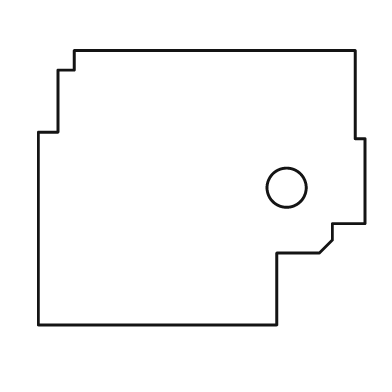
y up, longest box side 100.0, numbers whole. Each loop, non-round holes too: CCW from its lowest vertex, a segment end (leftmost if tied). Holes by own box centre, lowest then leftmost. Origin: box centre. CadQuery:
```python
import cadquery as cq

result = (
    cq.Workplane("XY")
    .moveTo(-50.0, -42.0)
    .lineTo(23.0, -42.0)
    .lineTo(23.0, -20.0)
    .lineTo(36.0, -20.0)
    .lineTo(40.0, -16.0)
    .lineTo(40.0, -11.0)
    .lineTo(50.0, -11.0)
    .lineTo(50.0, 15.0)
    .lineTo(47.0, 15.0)
    .lineTo(47.0, 42.0)
    .lineTo(-39.0, 42.0)
    .lineTo(-39.0, 36.0)
    .lineTo(-44.0, 36.0)
    .lineTo(-44.0, 17.0)
    .lineTo(-50.0, 17.0)
    .close()
    .moveTo(26.0, 0.0)
    .circle(6.0)
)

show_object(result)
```